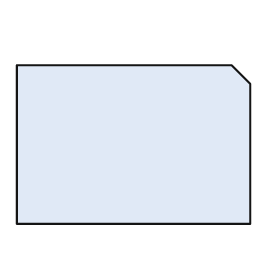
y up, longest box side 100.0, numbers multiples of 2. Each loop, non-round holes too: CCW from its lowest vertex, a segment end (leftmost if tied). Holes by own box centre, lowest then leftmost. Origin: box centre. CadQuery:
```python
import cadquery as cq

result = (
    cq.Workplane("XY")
    .moveTo(-50.0, -34.0)
    .lineTo(50.0, -34.0)
    .lineTo(50.0, 26.0)
    .lineTo(42.0, 34.0)
    .lineTo(-50.0, 34.0)
    .close()
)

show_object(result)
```